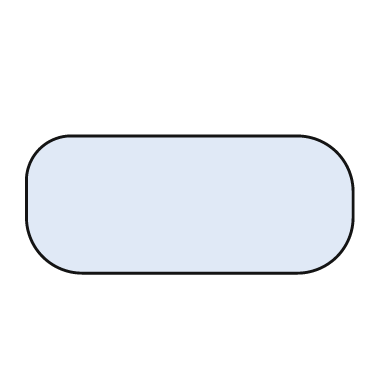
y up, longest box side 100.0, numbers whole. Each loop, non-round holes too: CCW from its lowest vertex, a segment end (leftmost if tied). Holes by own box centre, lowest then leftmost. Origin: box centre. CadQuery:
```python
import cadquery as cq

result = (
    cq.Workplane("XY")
    .moveTo(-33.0, -21.0)
    .lineTo(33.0, -21.0)
    .threePointArc((45.0, -16.0), (50.0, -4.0))
    .lineTo(50.0, 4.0)
    .threePointArc((45.0, 16.0), (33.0, 21.0))
    .lineTo(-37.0, 21.0)
    .threePointArc((-46.0, 17.0), (-50.0, 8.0))
    .lineTo(-50.0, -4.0)
    .threePointArc((-45.0, -16.0), (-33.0, -21.0))
    .close()
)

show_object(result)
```